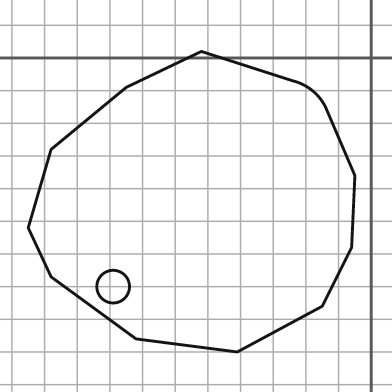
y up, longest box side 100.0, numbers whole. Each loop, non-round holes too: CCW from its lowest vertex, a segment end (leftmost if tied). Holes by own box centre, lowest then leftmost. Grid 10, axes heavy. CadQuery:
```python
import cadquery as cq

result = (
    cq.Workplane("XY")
    .moveTo(-41.0, -90.0)
    .lineTo(-15.0, -76.0)
    .lineTo(-6.0, -58.0)
    .lineTo(-5.0, -36.0)
    .lineTo(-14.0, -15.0)
    .threePointArc((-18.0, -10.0), (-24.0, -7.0))
    .lineTo(-52.0, 2.0)
    .lineTo(-75.0, -9.0)
    .lineTo(-98.0, -28.0)
    .lineTo(-105.0, -52.0)
    .lineTo(-98.0, -67.0)
    .lineTo(-72.0, -86.0)
    .close()
    .moveTo(-79.0, -70.0)
    .circle(5.0)
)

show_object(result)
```